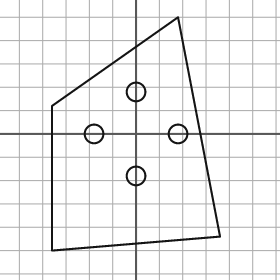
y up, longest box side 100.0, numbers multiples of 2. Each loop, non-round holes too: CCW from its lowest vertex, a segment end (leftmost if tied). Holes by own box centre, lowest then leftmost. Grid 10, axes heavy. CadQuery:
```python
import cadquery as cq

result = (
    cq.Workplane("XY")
    .moveTo(-36.0, -50.0)
    .lineTo(36.0, -44.0)
    .lineTo(18.0, 50.0)
    .lineTo(-36.0, 12.0)
    .close()
    .moveTo(0.0, -18.0)
    .circle(4.0)
    .moveTo(-18.0, 0.0)
    .circle(4.0)
    .moveTo(18.0, 0.0)
    .circle(4.0)
    .moveTo(0.0, 18.0)
    .circle(4.0)
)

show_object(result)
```